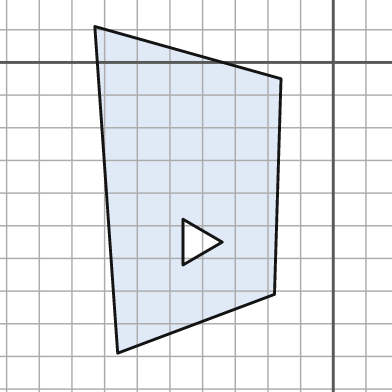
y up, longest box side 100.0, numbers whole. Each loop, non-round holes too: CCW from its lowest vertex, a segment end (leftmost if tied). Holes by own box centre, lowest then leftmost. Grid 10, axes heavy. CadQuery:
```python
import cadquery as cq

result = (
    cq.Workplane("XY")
    .moveTo(-66.0, -89.0)
    .lineTo(-18.0, -71.0)
    .lineTo(-16.0, -5.0)
    .lineTo(-73.0, 11.0)
    .close()
    .moveTo(-46.0, -62.0)
    .lineTo(-34.0, -55.0)
    .lineTo(-46.0, -48.0)
    .close()
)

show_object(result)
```